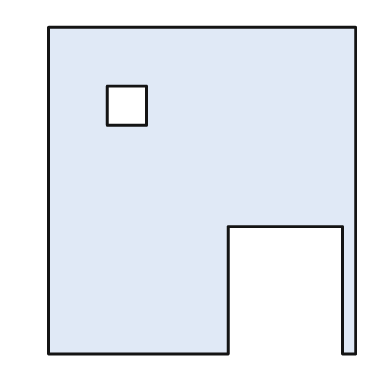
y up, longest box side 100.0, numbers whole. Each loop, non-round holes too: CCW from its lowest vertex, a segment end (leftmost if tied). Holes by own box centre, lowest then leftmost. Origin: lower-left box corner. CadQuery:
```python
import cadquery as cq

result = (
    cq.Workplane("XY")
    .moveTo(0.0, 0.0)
    .lineTo(55.0, 0.0)
    .lineTo(55.0, 39.0)
    .lineTo(90.0, 39.0)
    .lineTo(90.0, 0.0)
    .lineTo(94.0, 0.0)
    .lineTo(94.0, 100.0)
    .lineTo(0.0, 100.0)
    .close()
    .moveTo(18.0, 70.0)
    .lineTo(30.0, 70.0)
    .lineTo(30.0, 82.0)
    .lineTo(18.0, 82.0)
    .close()
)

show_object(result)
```